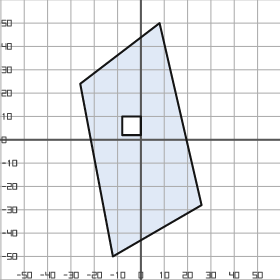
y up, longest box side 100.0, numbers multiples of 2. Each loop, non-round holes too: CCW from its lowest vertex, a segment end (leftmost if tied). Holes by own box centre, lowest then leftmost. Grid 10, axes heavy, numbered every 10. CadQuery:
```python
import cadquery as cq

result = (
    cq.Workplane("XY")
    .moveTo(-12.0, -50.0)
    .lineTo(26.0, -28.0)
    .lineTo(8.0, 50.0)
    .lineTo(-26.0, 24.0)
    .close()
    .moveTo(-8.0, 2.0)
    .lineTo(0.0, 2.0)
    .lineTo(0.0, 10.0)
    .lineTo(-8.0, 10.0)
    .close()
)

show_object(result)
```